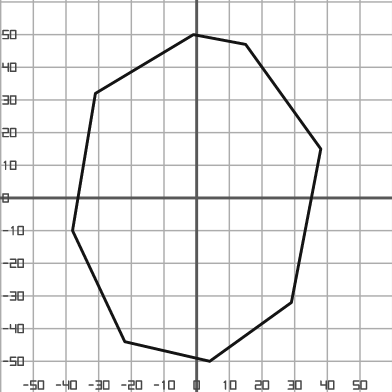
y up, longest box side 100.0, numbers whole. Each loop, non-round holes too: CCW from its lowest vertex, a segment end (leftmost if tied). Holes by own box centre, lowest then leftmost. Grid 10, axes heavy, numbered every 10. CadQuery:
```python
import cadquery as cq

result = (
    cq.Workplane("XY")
    .moveTo(4.0, -50.0)
    .lineTo(29.0, -32.0)
    .lineTo(38.0, 15.0)
    .lineTo(15.0, 47.0)
    .lineTo(-1.0, 50.0)
    .lineTo(-31.0, 32.0)
    .lineTo(-38.0, -10.0)
    .lineTo(-22.0, -44.0)
    .close()
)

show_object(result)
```